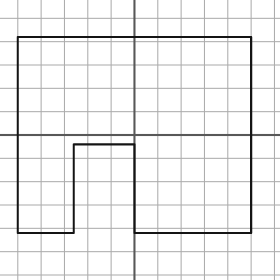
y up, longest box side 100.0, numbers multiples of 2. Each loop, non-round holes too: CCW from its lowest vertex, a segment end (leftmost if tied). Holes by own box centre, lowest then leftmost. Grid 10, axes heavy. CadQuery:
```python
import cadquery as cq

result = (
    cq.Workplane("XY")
    .moveTo(-50.0, -42.0)
    .lineTo(-26.0, -42.0)
    .lineTo(-26.0, -4.0)
    .lineTo(0.0, -4.0)
    .lineTo(0.0, -42.0)
    .lineTo(50.0, -42.0)
    .lineTo(50.0, 42.0)
    .lineTo(-50.0, 42.0)
    .close()
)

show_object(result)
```